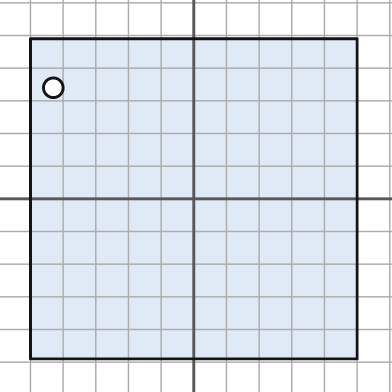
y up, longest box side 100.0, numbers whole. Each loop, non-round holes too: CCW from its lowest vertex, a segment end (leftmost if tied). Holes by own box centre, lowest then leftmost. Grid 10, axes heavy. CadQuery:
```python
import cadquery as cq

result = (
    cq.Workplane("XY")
    .moveTo(-50.0, -49.0)
    .lineTo(50.0, -49.0)
    .lineTo(50.0, 49.0)
    .lineTo(-50.0, 49.0)
    .close()
    .moveTo(-43.0, 34.0)
    .circle(3.0)
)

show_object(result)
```